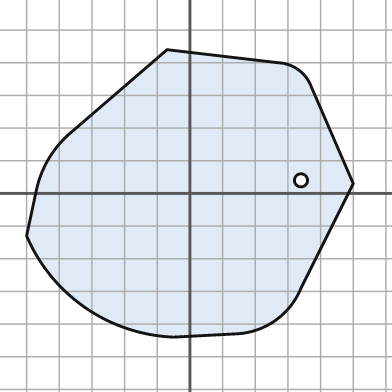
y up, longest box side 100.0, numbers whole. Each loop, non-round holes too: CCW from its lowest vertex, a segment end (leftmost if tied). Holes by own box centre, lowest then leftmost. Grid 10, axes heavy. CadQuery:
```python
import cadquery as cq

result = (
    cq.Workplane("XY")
    .moveTo(-5.0, -44.0)
    .lineTo(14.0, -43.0)
    .threePointArc((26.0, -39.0), (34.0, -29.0))
    .lineTo(50.0, 3.0)
    .lineTo(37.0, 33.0)
    .threePointArc((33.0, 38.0), (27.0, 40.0))
    .lineTo(-7.0, 44.0)
    .lineTo(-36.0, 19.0)
    .threePointArc((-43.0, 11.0), (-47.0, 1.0))
    .lineTo(-50.0, -13.0)
    .threePointArc((-32.0, -35.0), (-5.0, -44.0))
    .close()
    .moveTo(34.0, 4.0)
    .circle(2.0)
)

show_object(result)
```